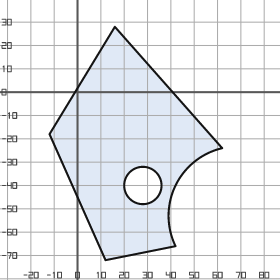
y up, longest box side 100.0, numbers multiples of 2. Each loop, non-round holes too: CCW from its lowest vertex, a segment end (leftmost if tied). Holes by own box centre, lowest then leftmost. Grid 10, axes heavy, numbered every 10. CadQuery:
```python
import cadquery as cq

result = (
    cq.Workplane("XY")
    .moveTo(12.0, -72.0)
    .lineTo(42.0, -66.0)
    .threePointArc((42.0, -40.0), (62.0, -24.0))
    .lineTo(16.0, 28.0)
    .lineTo(-12.0, -18.0)
    .close()
    .moveTo(28.0, -40.0)
    .circle(8.0)
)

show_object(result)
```